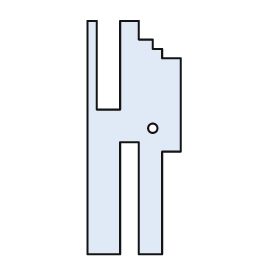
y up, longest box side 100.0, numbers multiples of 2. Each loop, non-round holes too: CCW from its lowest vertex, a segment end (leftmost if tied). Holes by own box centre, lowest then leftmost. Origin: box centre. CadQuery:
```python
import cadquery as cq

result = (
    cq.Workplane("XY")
    .moveTo(-20.0, -50.0)
    .lineTo(-6.0, -50.0)
    .lineTo(-6.0, -2.0)
    .lineTo(2.0, -2.0)
    .lineTo(2.0, -50.0)
    .lineTo(12.0, -50.0)
    .lineTo(12.0, -6.0)
    .lineTo(20.0, -6.0)
    .lineTo(20.0, 34.0)
    .lineTo(12.0, 34.0)
    .lineTo(12.0, 38.0)
    .lineTo(8.0, 38.0)
    .lineTo(8.0, 42.0)
    .lineTo(2.0, 42.0)
    .lineTo(2.0, 50.0)
    .lineTo(-6.0, 50.0)
    .lineTo(-6.0, 12.0)
    .lineTo(-16.0, 12.0)
    .lineTo(-16.0, 50.0)
    .lineTo(-20.0, 50.0)
    .close()
    .moveTo(8.0, 4.0)
    .circle(2.0)
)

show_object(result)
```